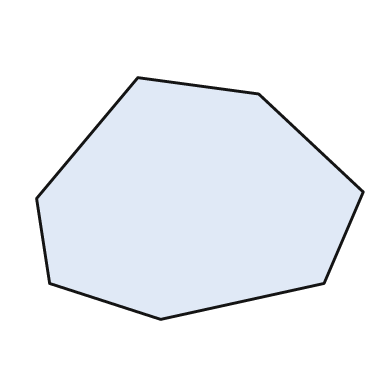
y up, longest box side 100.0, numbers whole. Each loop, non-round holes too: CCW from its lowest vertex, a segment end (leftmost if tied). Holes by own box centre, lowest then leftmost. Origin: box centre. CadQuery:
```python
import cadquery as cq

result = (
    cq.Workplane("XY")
    .moveTo(-12.0, -37.0)
    .lineTo(38.0, -26.0)
    .lineTo(50.0, 2.0)
    .lineTo(18.0, 32.0)
    .lineTo(-19.0, 37.0)
    .lineTo(-50.0, 0.0)
    .lineTo(-46.0, -26.0)
    .close()
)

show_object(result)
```